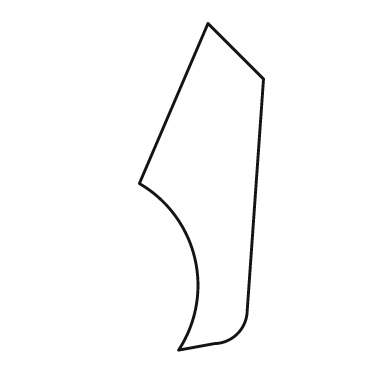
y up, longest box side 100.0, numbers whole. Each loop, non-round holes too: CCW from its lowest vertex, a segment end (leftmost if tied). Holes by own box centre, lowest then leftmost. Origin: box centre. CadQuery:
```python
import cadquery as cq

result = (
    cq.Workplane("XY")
    .moveTo(-7.0, -50.0)
    .lineTo(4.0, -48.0)
    .threePointArc((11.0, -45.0), (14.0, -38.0))
    .lineTo(19.0, 33.0)
    .lineTo(2.0, 50.0)
    .lineTo(-19.0, 1.0)
    .threePointArc((-2.0, -22.0), (-7.0, -50.0))
    .close()
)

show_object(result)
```